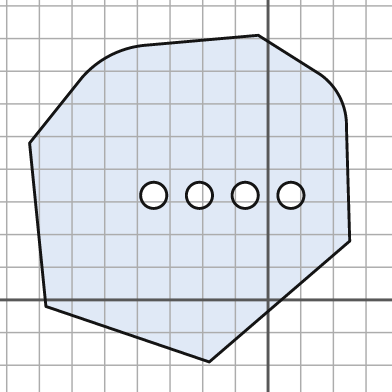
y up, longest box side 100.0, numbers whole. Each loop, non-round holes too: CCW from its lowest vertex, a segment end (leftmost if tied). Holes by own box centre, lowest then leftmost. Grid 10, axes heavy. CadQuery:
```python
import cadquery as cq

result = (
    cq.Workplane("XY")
    .moveTo(-18.0, -19.0)
    .lineTo(25.0, 18.0)
    .lineTo(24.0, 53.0)
    .threePointArc((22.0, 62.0), (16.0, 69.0))
    .lineTo(-3.0, 81.0)
    .lineTo(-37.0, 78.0)
    .threePointArc((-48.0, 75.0), (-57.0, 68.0))
    .lineTo(-73.0, 48.0)
    .lineTo(-68.0, -2.0)
    .close()
    .moveTo(-35.0, 32.0)
    .circle(4.0)
    .moveTo(-21.0, 32.0)
    .circle(4.0)
    .moveTo(-7.0, 32.0)
    .circle(4.0)
    .moveTo(7.0, 32.0)
    .circle(4.0)
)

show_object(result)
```